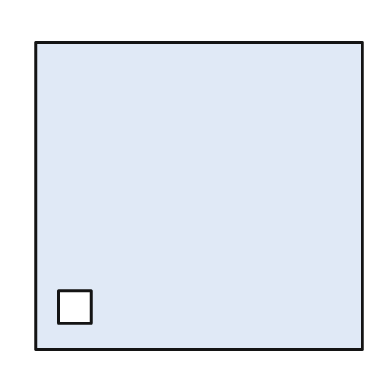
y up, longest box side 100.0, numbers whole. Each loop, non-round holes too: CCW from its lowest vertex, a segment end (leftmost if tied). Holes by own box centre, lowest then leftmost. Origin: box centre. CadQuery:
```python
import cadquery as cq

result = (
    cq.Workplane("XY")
    .moveTo(-50.0, -47.0)
    .lineTo(50.0, -47.0)
    .lineTo(50.0, 47.0)
    .lineTo(-50.0, 47.0)
    .close()
    .moveTo(-43.0, -39.0)
    .lineTo(-33.0, -39.0)
    .lineTo(-33.0, -29.0)
    .lineTo(-43.0, -29.0)
    .close()
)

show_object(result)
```